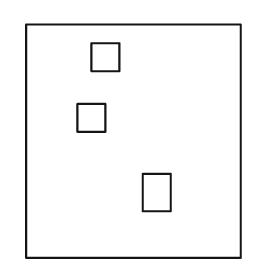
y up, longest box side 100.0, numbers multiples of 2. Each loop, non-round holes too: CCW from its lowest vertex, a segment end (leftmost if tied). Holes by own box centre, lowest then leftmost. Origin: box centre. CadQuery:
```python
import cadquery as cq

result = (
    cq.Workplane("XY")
    .moveTo(-46.0, -50.0)
    .lineTo(46.0, -50.0)
    .lineTo(46.0, 50.0)
    .lineTo(-46.0, 50.0)
    .close()
    .moveTo(4.0, -30.0)
    .lineTo(16.0, -30.0)
    .lineTo(16.0, -14.0)
    .lineTo(4.0, -14.0)
    .close()
    .moveTo(-24.0, 4.0)
    .lineTo(-12.0, 4.0)
    .lineTo(-12.0, 16.0)
    .lineTo(-24.0, 16.0)
    .close()
    .moveTo(-18.0, 30.0)
    .lineTo(-6.0, 30.0)
    .lineTo(-6.0, 42.0)
    .lineTo(-18.0, 42.0)
    .close()
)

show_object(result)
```